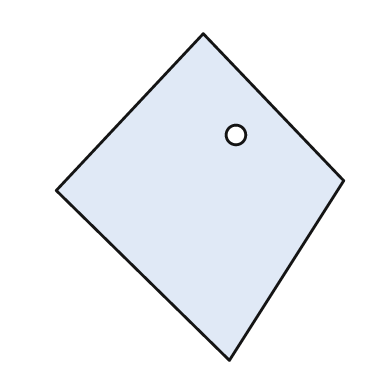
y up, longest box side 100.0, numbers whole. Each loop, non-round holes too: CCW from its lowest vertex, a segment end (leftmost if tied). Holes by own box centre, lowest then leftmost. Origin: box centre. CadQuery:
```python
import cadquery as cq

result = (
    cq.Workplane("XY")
    .moveTo(9.0, -50.0)
    .lineTo(44.0, 5.0)
    .lineTo(1.0, 50.0)
    .lineTo(-44.0, 2.0)
    .close()
    .moveTo(11.0, 19.0)
    .circle(3.0)
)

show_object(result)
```